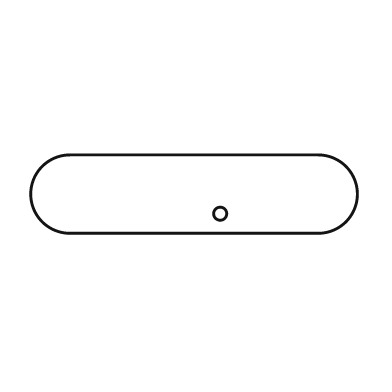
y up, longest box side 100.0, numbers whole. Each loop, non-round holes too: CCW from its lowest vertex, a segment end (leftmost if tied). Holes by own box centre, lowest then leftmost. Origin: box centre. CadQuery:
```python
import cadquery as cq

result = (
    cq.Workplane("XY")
    .moveTo(-38.0, -12.0)
    .lineTo(38.0, -12.0)
    .threePointArc((50.0, 0.0), (38.0, 12.0))
    .lineTo(-38.0, 12.0)
    .threePointArc((-50.0, 0.0), (-38.0, -12.0))
    .close()
    .moveTo(8.0, -6.0)
    .circle(2.0)
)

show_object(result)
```